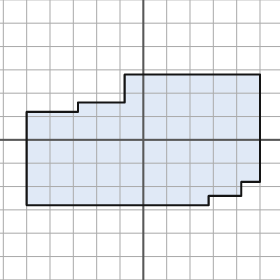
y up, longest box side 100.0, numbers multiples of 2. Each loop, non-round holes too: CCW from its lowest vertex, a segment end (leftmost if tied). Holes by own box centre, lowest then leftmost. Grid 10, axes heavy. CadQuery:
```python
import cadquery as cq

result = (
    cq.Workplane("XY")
    .moveTo(-50.0, -28.0)
    .lineTo(28.0, -28.0)
    .lineTo(28.0, -24.0)
    .lineTo(42.0, -24.0)
    .lineTo(42.0, -18.0)
    .lineTo(50.0, -18.0)
    .lineTo(50.0, 28.0)
    .lineTo(-8.0, 28.0)
    .lineTo(-8.0, 16.0)
    .lineTo(-28.0, 16.0)
    .lineTo(-28.0, 12.0)
    .lineTo(-50.0, 12.0)
    .close()
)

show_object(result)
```